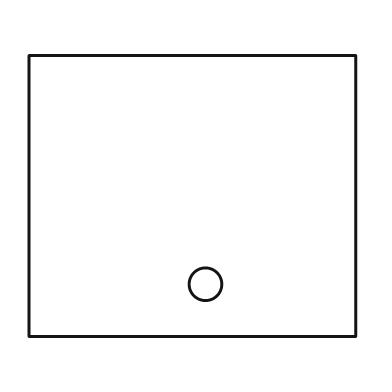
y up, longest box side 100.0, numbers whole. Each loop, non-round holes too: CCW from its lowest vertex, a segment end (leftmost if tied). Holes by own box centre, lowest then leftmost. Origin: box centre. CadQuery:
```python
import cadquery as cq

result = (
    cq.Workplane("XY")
    .moveTo(-50.0, -43.0)
    .lineTo(50.0, -43.0)
    .lineTo(50.0, 43.0)
    .lineTo(-50.0, 43.0)
    .close()
    .moveTo(4.0, -27.0)
    .circle(5.0)
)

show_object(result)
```